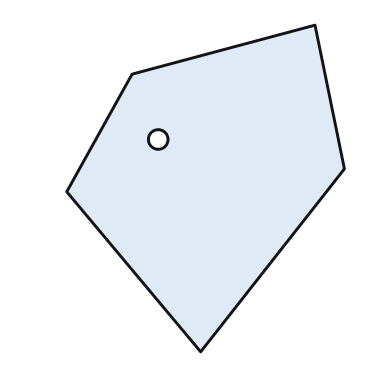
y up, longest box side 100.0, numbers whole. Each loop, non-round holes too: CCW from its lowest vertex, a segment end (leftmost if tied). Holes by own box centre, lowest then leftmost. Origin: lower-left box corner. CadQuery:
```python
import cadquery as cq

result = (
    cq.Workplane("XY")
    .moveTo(41.0, 0.0)
    .lineTo(85.0, 56.0)
    .lineTo(76.0, 100.0)
    .lineTo(20.0, 85.0)
    .lineTo(0.0, 49.0)
    .close()
    .moveTo(28.0, 65.0)
    .circle(3.0)
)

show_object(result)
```